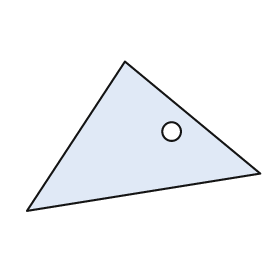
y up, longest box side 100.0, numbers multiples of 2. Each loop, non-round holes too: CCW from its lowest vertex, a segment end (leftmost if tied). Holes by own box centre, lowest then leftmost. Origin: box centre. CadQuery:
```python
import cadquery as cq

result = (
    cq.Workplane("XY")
    .moveTo(-50.0, -32.0)
    .lineTo(50.0, -16.0)
    .lineTo(-8.0, 32.0)
    .close()
    .moveTo(12.0, 2.0)
    .circle(4.0)
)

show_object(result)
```